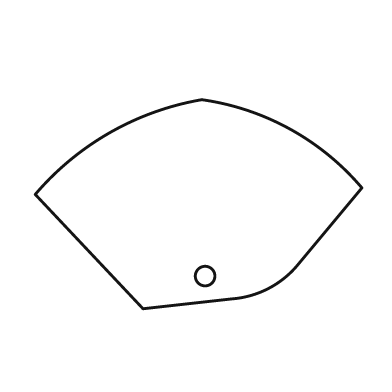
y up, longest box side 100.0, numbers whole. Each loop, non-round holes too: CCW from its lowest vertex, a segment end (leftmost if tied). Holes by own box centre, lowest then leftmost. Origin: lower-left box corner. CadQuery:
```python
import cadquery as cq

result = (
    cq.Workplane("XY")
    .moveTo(33.0, 0.0)
    .lineTo(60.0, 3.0)
    .threePointArc((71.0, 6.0), (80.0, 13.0))
    .lineTo(100.0, 37.0)
    .threePointArc((78.0, 55.0), (51.0, 64.0))
    .threePointArc((23.0, 54.0), (0.0, 35.0))
    .close()
    .moveTo(52.0, 10.0)
    .circle(3.0)
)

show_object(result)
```